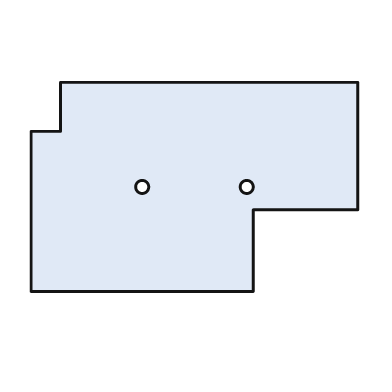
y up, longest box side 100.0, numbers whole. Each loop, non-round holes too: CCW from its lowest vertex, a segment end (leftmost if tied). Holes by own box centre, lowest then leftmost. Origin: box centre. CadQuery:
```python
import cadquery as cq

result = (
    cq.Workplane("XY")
    .moveTo(-50.0, -32.0)
    .lineTo(18.0, -32.0)
    .lineTo(18.0, -7.0)
    .lineTo(50.0, -7.0)
    .lineTo(50.0, 32.0)
    .lineTo(-41.0, 32.0)
    .lineTo(-41.0, 17.0)
    .lineTo(-50.0, 17.0)
    .close()
    .moveTo(-16.0, 0.0)
    .circle(2.0)
    .moveTo(16.0, 0.0)
    .circle(2.0)
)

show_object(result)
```